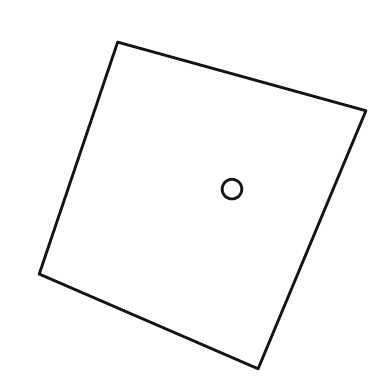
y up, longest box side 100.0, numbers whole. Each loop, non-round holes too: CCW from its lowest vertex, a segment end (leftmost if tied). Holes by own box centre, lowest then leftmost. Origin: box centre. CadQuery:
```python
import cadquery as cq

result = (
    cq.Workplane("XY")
    .moveTo(17.0, -50.0)
    .lineTo(50.0, 29.0)
    .lineTo(-26.0, 50.0)
    .lineTo(-50.0, -21.0)
    .close()
    .moveTo(9.0, 5.0)
    .circle(3.0)
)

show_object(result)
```